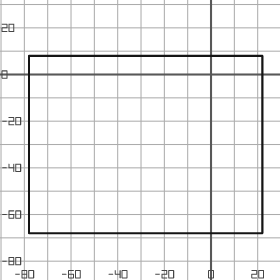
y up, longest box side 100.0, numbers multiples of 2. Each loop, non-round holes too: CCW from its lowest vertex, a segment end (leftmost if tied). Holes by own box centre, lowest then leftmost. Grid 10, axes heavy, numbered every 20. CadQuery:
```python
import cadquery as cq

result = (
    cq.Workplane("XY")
    .moveTo(-78.0, -68.0)
    .lineTo(22.0, -68.0)
    .lineTo(22.0, 8.0)
    .lineTo(-78.0, 8.0)
    .close()
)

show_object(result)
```